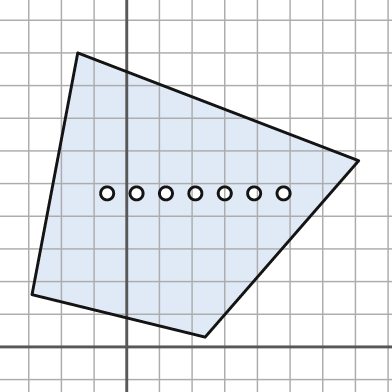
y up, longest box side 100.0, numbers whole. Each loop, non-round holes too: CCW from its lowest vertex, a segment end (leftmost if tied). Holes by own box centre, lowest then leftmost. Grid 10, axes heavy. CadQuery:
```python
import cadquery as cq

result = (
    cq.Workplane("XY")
    .moveTo(24.0, 3.0)
    .lineTo(71.0, 57.0)
    .lineTo(-15.0, 90.0)
    .lineTo(-29.0, 16.0)
    .close()
    .moveTo(-6.0, 47.0)
    .circle(2.0)
    .moveTo(3.0, 47.0)
    .circle(2.0)
    .moveTo(12.0, 47.0)
    .circle(2.0)
    .moveTo(21.0, 47.0)
    .circle(2.0)
    .moveTo(30.0, 47.0)
    .circle(2.0)
    .moveTo(39.0, 47.0)
    .circle(2.0)
    .moveTo(48.0, 47.0)
    .circle(2.0)
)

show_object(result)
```